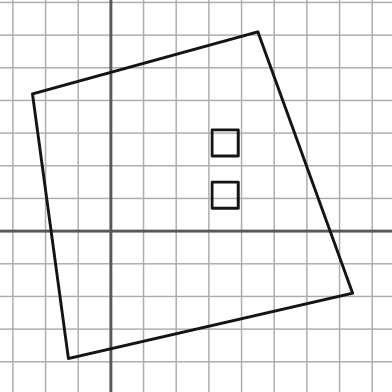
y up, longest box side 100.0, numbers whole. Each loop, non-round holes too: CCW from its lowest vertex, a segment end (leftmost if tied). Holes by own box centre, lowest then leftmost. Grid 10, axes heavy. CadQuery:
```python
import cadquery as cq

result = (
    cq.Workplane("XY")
    .moveTo(-13.0, -39.0)
    .lineTo(74.0, -19.0)
    .lineTo(45.0, 61.0)
    .lineTo(-24.0, 42.0)
    .close()
    .moveTo(31.0, 7.0)
    .lineTo(39.0, 7.0)
    .lineTo(39.0, 15.0)
    .lineTo(31.0, 15.0)
    .close()
    .moveTo(31.0, 23.0)
    .lineTo(39.0, 23.0)
    .lineTo(39.0, 31.0)
    .lineTo(31.0, 31.0)
    .close()
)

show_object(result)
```